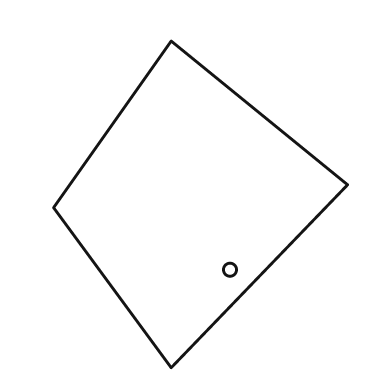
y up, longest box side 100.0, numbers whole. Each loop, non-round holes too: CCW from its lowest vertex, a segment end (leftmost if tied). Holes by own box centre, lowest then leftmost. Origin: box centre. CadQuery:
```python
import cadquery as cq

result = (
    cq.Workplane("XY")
    .moveTo(-9.0, -50.0)
    .lineTo(45.0, 6.0)
    .lineTo(-9.0, 50.0)
    .lineTo(-45.0, -1.0)
    .close()
    .moveTo(9.0, -20.0)
    .circle(2.0)
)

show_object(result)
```